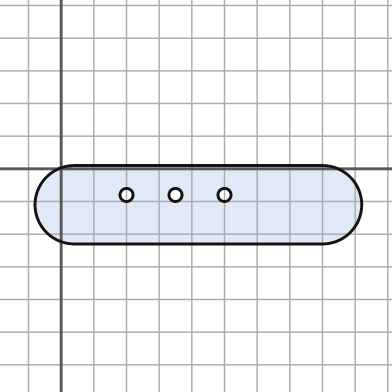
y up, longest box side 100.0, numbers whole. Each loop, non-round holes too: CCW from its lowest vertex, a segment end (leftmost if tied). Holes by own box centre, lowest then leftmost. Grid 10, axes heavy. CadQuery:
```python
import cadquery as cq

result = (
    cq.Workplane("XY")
    .moveTo(4.0, -23.0)
    .lineTo(80.0, -23.0)
    .threePointArc((92.0, -11.0), (80.0, 1.0))
    .lineTo(4.0, 1.0)
    .threePointArc((-8.0, -11.0), (4.0, -23.0))
    .close()
    .moveTo(20.0, -8.0)
    .circle(2.0)
    .moveTo(35.0, -8.0)
    .circle(2.0)
    .moveTo(50.0, -8.0)
    .circle(2.0)
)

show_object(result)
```